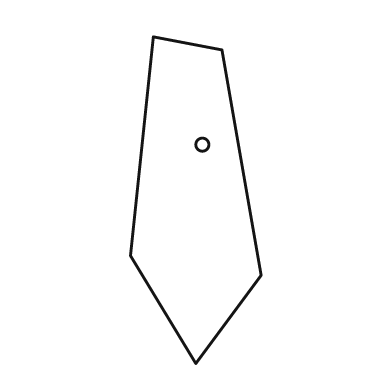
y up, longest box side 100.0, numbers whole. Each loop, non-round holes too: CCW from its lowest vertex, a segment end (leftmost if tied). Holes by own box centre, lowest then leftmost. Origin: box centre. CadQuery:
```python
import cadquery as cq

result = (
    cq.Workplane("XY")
    .moveTo(0.0, -50.0)
    .lineTo(20.0, -23.0)
    .lineTo(8.0, 46.0)
    .lineTo(-13.0, 50.0)
    .lineTo(-20.0, -17.0)
    .close()
    .moveTo(2.0, 17.0)
    .circle(2.0)
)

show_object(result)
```